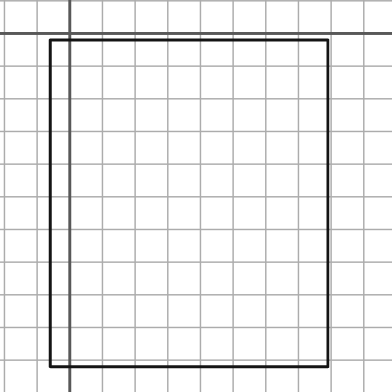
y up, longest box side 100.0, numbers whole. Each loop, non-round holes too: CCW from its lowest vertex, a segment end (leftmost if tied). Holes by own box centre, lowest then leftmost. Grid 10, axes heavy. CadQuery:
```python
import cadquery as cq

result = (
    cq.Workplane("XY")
    .moveTo(-6.0, -102.0)
    .lineTo(79.0, -102.0)
    .lineTo(79.0, -2.0)
    .lineTo(-6.0, -2.0)
    .close()
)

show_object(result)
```